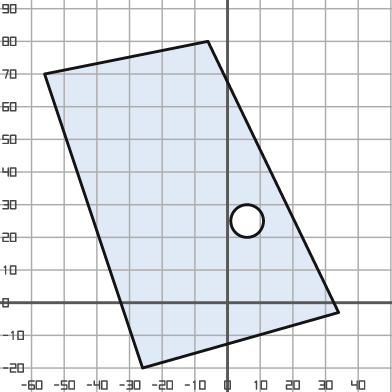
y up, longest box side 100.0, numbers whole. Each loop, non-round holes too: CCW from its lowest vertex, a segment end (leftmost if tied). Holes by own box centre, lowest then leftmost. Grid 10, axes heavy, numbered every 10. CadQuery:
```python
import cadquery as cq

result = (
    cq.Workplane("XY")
    .moveTo(-26.0, -20.0)
    .lineTo(34.0, -3.0)
    .lineTo(-6.0, 80.0)
    .lineTo(-56.0, 70.0)
    .close()
    .moveTo(6.0, 25.0)
    .circle(5.0)
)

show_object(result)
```